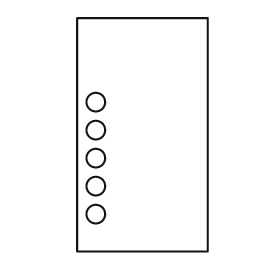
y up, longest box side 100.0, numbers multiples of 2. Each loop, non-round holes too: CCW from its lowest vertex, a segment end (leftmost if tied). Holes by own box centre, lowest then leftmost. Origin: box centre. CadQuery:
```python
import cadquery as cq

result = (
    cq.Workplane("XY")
    .moveTo(-28.0, -50.0)
    .lineTo(28.0, -50.0)
    .lineTo(28.0, 50.0)
    .lineTo(-28.0, 50.0)
    .close()
    .moveTo(-20.0, -34.0)
    .circle(4.0)
    .moveTo(-20.0, -22.0)
    .circle(4.0)
    .moveTo(-20.0, -10.0)
    .circle(4.0)
    .moveTo(-20.0, 2.0)
    .circle(4.0)
    .moveTo(-20.0, 14.0)
    .circle(4.0)
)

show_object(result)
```